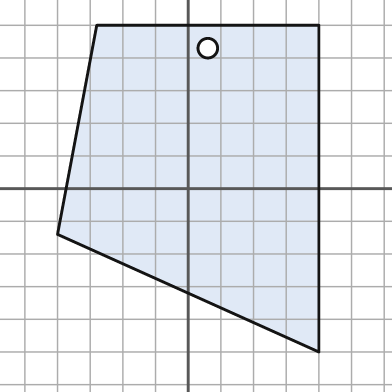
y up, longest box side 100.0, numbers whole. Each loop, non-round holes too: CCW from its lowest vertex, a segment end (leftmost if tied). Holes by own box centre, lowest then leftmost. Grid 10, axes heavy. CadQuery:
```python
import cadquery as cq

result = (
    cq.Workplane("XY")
    .moveTo(40.0, -50.0)
    .lineTo(40.0, 50.0)
    .lineTo(-28.0, 50.0)
    .lineTo(-40.0, -14.0)
    .close()
    .moveTo(6.0, 43.0)
    .circle(3.0)
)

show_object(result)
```